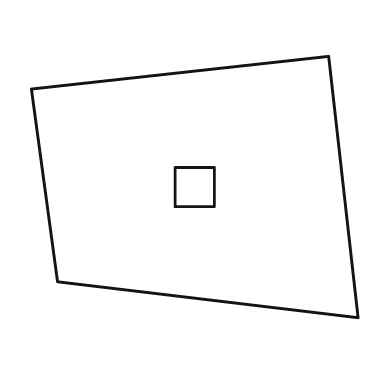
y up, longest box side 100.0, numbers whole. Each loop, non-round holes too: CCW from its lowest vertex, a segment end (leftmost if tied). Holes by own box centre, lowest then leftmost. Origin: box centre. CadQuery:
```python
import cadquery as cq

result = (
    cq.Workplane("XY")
    .moveTo(50.0, -40.0)
    .lineTo(41.0, 40.0)
    .lineTo(-50.0, 30.0)
    .lineTo(-42.0, -29.0)
    .close()
    .moveTo(-6.0, -6.0)
    .lineTo(6.0, -6.0)
    .lineTo(6.0, 6.0)
    .lineTo(-6.0, 6.0)
    .close()
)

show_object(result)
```